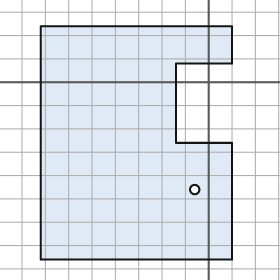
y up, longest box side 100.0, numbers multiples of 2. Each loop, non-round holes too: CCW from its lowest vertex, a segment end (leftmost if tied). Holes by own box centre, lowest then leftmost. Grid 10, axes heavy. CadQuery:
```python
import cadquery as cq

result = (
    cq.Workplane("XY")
    .moveTo(-72.0, -76.0)
    .lineTo(10.0, -76.0)
    .lineTo(10.0, -26.0)
    .lineTo(-14.0, -26.0)
    .lineTo(-14.0, 8.0)
    .lineTo(10.0, 8.0)
    .lineTo(10.0, 24.0)
    .lineTo(-72.0, 24.0)
    .close()
    .moveTo(-6.0, -46.0)
    .circle(2.0)
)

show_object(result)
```